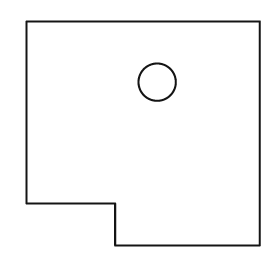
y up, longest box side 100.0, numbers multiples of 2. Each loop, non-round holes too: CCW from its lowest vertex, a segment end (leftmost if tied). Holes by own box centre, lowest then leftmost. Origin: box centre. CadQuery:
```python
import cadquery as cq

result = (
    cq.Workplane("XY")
    .moveTo(-12.0, -48.0)
    .lineTo(50.0, -48.0)
    .lineTo(50.0, 48.0)
    .lineTo(-50.0, 48.0)
    .lineTo(-50.0, -30.0)
    .lineTo(-12.0, -30.0)
    .close()
    .moveTo(6.0, 22.0)
    .circle(8.0)
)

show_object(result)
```